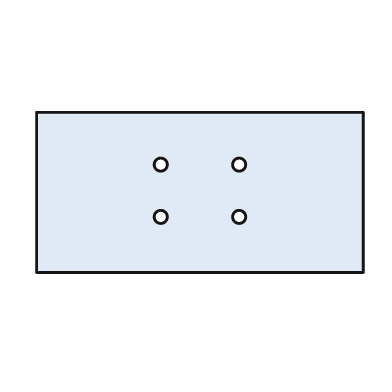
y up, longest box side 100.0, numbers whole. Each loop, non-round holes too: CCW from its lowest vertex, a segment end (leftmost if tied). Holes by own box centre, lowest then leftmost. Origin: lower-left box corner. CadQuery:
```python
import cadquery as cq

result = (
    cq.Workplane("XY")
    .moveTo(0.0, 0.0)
    .lineTo(100.0, 0.0)
    .lineTo(100.0, 49.0)
    .lineTo(0.0, 49.0)
    .close()
    .moveTo(38.0, 17.0)
    .circle(2.0)
    .moveTo(62.0, 17.0)
    .circle(2.0)
    .moveTo(38.0, 33.0)
    .circle(2.0)
    .moveTo(62.0, 33.0)
    .circle(2.0)
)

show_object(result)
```